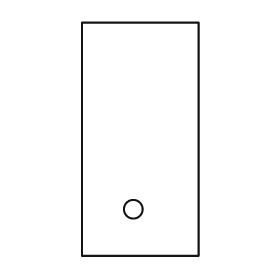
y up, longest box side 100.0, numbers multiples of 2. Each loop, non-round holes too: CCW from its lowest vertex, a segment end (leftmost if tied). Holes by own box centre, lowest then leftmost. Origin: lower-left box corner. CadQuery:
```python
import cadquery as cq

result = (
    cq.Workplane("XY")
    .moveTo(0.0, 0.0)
    .lineTo(50.0, 0.0)
    .lineTo(50.0, 100.0)
    .lineTo(0.0, 100.0)
    .close()
    .moveTo(22.0, 20.0)
    .circle(4.0)
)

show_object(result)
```